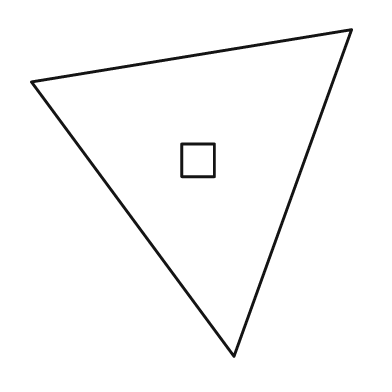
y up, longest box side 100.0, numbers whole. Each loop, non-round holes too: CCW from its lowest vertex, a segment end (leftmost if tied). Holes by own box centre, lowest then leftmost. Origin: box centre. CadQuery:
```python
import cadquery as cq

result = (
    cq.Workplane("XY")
    .moveTo(13.0, -50.0)
    .lineTo(49.0, 50.0)
    .lineTo(-49.0, 34.0)
    .close()
    .moveTo(-3.0, 5.0)
    .lineTo(7.0, 5.0)
    .lineTo(7.0, 15.0)
    .lineTo(-3.0, 15.0)
    .close()
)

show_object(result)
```